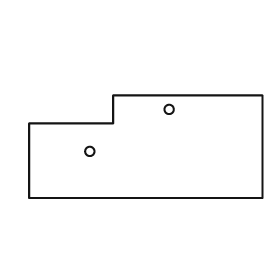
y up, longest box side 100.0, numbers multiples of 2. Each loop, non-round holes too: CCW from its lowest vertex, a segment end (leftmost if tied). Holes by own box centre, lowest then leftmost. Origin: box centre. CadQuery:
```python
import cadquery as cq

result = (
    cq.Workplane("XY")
    .moveTo(-50.0, -22.0)
    .lineTo(50.0, -22.0)
    .lineTo(50.0, 22.0)
    .lineTo(-14.0, 22.0)
    .lineTo(-14.0, 10.0)
    .lineTo(-50.0, 10.0)
    .close()
    .moveTo(-24.0, -2.0)
    .circle(2.0)
    .moveTo(10.0, 16.0)
    .circle(2.0)
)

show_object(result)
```